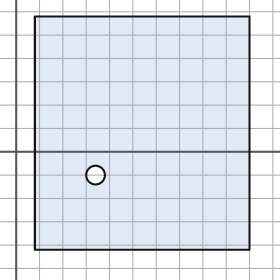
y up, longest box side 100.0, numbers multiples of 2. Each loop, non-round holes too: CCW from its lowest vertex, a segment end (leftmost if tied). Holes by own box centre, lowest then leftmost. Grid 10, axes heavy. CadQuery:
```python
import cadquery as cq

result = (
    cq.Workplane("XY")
    .moveTo(8.0, -42.0)
    .lineTo(100.0, -42.0)
    .lineTo(100.0, 58.0)
    .lineTo(8.0, 58.0)
    .close()
    .moveTo(34.0, -10.0)
    .circle(4.0)
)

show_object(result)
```